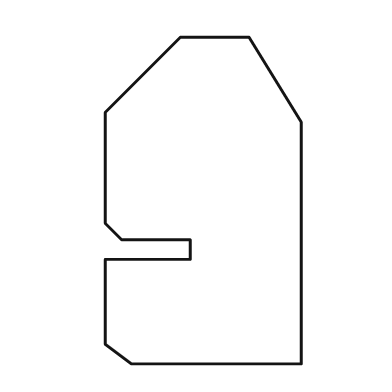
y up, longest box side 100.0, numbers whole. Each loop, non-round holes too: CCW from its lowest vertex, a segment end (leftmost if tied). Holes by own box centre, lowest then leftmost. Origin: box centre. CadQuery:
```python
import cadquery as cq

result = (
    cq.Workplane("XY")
    .moveTo(-22.0, -50.0)
    .lineTo(30.0, -50.0)
    .lineTo(30.0, 24.0)
    .lineTo(14.0, 50.0)
    .lineTo(-7.0, 50.0)
    .lineTo(-30.0, 27.0)
    .lineTo(-30.0, -7.0)
    .lineTo(-25.0, -12.0)
    .lineTo(-4.0, -12.0)
    .lineTo(-4.0, -18.0)
    .lineTo(-30.0, -18.0)
    .lineTo(-30.0, -44.0)
    .close()
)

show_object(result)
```